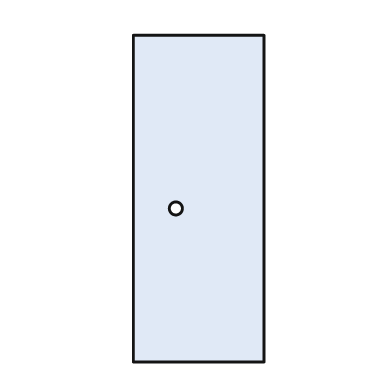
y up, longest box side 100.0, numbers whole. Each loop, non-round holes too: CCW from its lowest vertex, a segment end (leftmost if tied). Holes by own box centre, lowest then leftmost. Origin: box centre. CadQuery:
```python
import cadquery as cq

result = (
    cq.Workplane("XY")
    .moveTo(-20.0, -50.0)
    .lineTo(20.0, -50.0)
    .lineTo(20.0, 50.0)
    .lineTo(-20.0, 50.0)
    .close()
    .moveTo(-7.0, -3.0)
    .circle(2.0)
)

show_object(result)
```